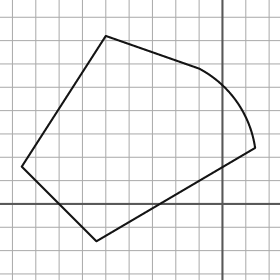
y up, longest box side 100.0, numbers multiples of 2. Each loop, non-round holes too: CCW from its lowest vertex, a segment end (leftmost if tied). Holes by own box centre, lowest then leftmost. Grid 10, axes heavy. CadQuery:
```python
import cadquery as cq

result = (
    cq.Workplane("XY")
    .moveTo(-54.0, -16.0)
    .lineTo(14.0, 24.0)
    .threePointArc((6.0, 44.0), (-10.0, 58.0))
    .lineTo(-50.0, 72.0)
    .lineTo(-86.0, 16.0)
    .close()
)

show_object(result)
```